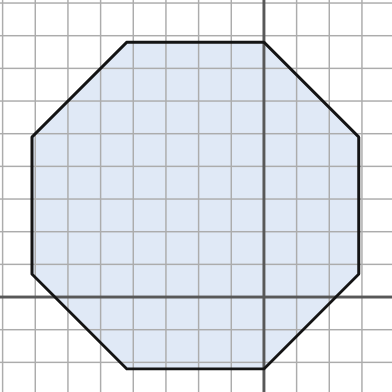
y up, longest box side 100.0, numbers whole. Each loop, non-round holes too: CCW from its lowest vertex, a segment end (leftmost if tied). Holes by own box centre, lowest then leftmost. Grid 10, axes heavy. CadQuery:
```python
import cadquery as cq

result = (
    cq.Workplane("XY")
    .moveTo(-42.0, -22.0)
    .lineTo(0.0, -22.0)
    .lineTo(29.0, 7.0)
    .lineTo(29.0, 49.0)
    .lineTo(0.0, 78.0)
    .lineTo(-42.0, 78.0)
    .lineTo(-71.0, 49.0)
    .lineTo(-71.0, 7.0)
    .close()
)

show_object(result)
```